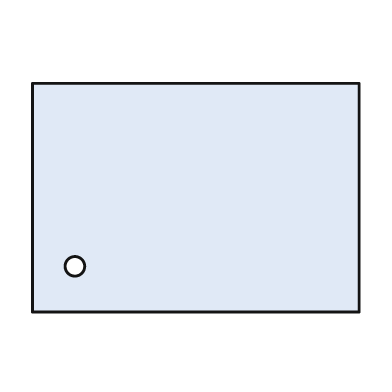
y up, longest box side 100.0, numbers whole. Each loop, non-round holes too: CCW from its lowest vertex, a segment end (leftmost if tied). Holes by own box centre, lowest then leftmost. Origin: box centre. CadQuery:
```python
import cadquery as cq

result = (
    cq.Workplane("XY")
    .moveTo(-50.0, -35.0)
    .lineTo(50.0, -35.0)
    .lineTo(50.0, 35.0)
    .lineTo(-50.0, 35.0)
    .close()
    .moveTo(-37.0, -21.0)
    .circle(3.0)
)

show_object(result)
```